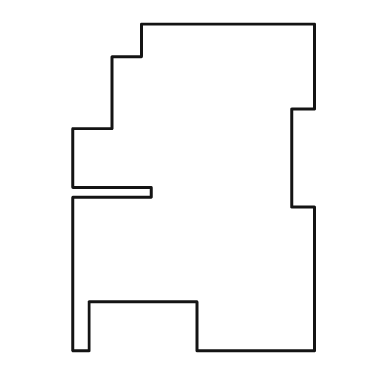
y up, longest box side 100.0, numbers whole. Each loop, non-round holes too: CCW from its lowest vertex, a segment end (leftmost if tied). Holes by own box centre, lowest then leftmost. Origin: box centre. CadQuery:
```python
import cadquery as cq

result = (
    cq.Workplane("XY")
    .moveTo(-37.0, -50.0)
    .lineTo(-32.0, -50.0)
    .lineTo(-32.0, -35.0)
    .lineTo(1.0, -35.0)
    .lineTo(1.0, -50.0)
    .lineTo(37.0, -50.0)
    .lineTo(37.0, -6.0)
    .lineTo(30.0, -6.0)
    .lineTo(30.0, 24.0)
    .lineTo(37.0, 24.0)
    .lineTo(37.0, 50.0)
    .lineTo(-16.0, 50.0)
    .lineTo(-16.0, 40.0)
    .lineTo(-25.0, 40.0)
    .lineTo(-25.0, 18.0)
    .lineTo(-37.0, 18.0)
    .lineTo(-37.0, 0.0)
    .lineTo(-13.0, 0.0)
    .lineTo(-13.0, -3.0)
    .lineTo(-37.0, -3.0)
    .close()
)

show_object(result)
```